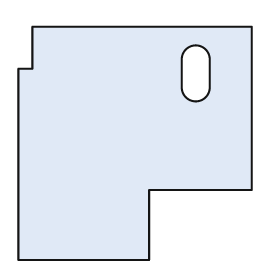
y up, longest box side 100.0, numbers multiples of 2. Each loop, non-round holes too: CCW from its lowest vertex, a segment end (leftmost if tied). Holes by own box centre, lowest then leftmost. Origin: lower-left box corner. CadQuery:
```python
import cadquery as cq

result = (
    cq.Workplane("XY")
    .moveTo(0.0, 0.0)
    .lineTo(56.0, 0.0)
    .lineTo(56.0, 30.0)
    .lineTo(100.0, 30.0)
    .lineTo(100.0, 100.0)
    .lineTo(6.0, 100.0)
    .lineTo(6.0, 82.0)
    .lineTo(0.0, 82.0)
    .close()
    .moveTo(70.0, 74.0)
    .threePointArc((76.0, 68.0), (82.0, 74.0))
    .lineTo(82.0, 86.0)
    .threePointArc((76.0, 92.0), (70.0, 86.0))
    .close()
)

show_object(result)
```